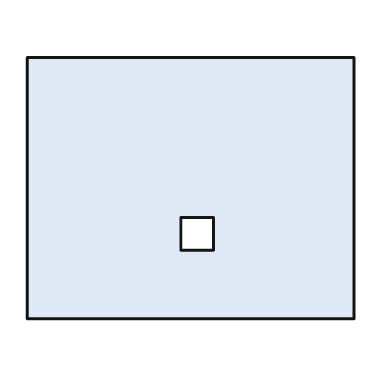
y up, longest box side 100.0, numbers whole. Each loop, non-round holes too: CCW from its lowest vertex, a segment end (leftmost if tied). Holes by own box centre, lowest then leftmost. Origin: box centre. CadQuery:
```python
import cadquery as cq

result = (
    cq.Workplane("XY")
    .moveTo(-50.0, -40.0)
    .lineTo(50.0, -40.0)
    .lineTo(50.0, 40.0)
    .lineTo(-50.0, 40.0)
    .close()
    .moveTo(-3.0, -19.0)
    .lineTo(7.0, -19.0)
    .lineTo(7.0, -9.0)
    .lineTo(-3.0, -9.0)
    .close()
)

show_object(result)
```